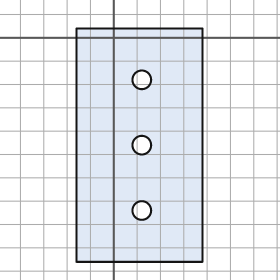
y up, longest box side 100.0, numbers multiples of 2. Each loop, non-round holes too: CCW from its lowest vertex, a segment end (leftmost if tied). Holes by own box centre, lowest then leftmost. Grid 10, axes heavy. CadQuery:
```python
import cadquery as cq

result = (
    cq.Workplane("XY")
    .moveTo(-16.0, -96.0)
    .lineTo(38.0, -96.0)
    .lineTo(38.0, 4.0)
    .lineTo(-16.0, 4.0)
    .close()
    .moveTo(12.0, -74.0)
    .circle(4.0)
    .moveTo(12.0, -46.0)
    .circle(4.0)
    .moveTo(12.0, -18.0)
    .circle(4.0)
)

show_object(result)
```